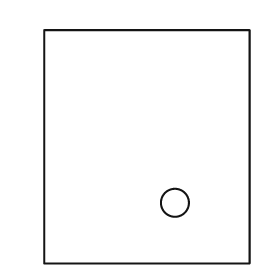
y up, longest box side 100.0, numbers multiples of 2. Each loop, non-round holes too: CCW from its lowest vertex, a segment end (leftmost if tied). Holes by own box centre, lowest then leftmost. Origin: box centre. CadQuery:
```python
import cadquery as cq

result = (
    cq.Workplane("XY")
    .moveTo(-44.0, -50.0)
    .lineTo(44.0, -50.0)
    .lineTo(44.0, 50.0)
    .lineTo(-44.0, 50.0)
    .close()
    .moveTo(12.0, -24.0)
    .circle(6.0)
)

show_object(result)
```